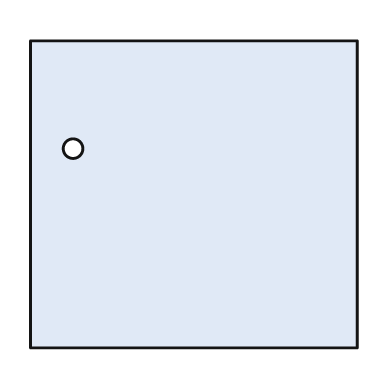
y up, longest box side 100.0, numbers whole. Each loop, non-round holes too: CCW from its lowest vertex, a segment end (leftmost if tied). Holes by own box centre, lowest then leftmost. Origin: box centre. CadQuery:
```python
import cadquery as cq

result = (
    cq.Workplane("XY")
    .moveTo(-50.0, -47.0)
    .lineTo(50.0, -47.0)
    .lineTo(50.0, 47.0)
    .lineTo(-50.0, 47.0)
    .close()
    .moveTo(-37.0, 14.0)
    .circle(3.0)
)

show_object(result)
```